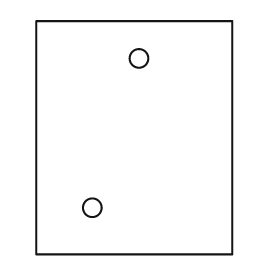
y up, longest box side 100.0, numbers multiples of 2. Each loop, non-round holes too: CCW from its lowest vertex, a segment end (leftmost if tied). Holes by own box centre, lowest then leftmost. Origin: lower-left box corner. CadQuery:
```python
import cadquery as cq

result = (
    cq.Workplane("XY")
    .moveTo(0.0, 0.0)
    .lineTo(84.0, 0.0)
    .lineTo(84.0, 100.0)
    .lineTo(0.0, 100.0)
    .close()
    .moveTo(24.0, 20.0)
    .circle(4.0)
    .moveTo(44.0, 84.0)
    .circle(4.0)
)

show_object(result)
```